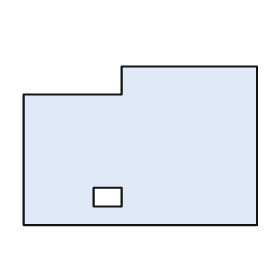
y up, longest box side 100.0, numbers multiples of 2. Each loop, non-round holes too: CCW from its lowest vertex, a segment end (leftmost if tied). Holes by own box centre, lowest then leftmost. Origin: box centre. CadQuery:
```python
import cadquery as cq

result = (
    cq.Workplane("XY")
    .moveTo(-50.0, -34.0)
    .lineTo(50.0, -34.0)
    .lineTo(50.0, 34.0)
    .lineTo(-8.0, 34.0)
    .lineTo(-8.0, 22.0)
    .lineTo(-50.0, 22.0)
    .close()
    .moveTo(-20.0, -26.0)
    .lineTo(-8.0, -26.0)
    .lineTo(-8.0, -18.0)
    .lineTo(-20.0, -18.0)
    .close()
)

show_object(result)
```